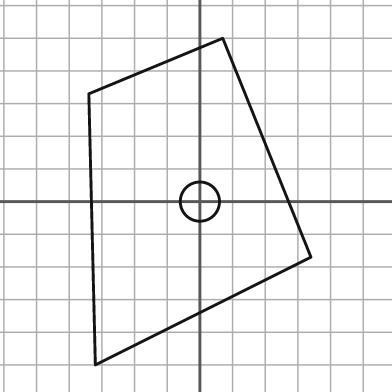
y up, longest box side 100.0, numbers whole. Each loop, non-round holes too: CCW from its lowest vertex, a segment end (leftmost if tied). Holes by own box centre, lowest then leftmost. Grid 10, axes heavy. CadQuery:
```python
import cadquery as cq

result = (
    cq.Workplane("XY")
    .moveTo(-32.0, -50.0)
    .lineTo(34.0, -17.0)
    .lineTo(7.0, 50.0)
    .lineTo(-34.0, 33.0)
    .close()
    .moveTo(0.0, 0.0)
    .circle(6.0)
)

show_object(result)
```